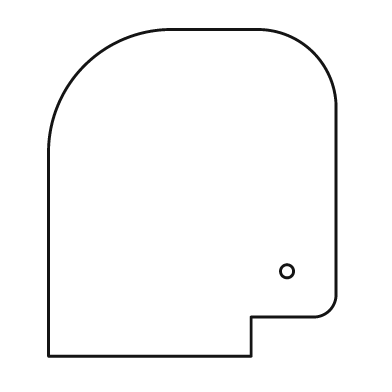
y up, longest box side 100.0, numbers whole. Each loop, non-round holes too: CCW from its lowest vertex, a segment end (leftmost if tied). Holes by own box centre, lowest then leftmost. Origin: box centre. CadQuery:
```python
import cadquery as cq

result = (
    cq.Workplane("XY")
    .moveTo(-44.0, -50.0)
    .lineTo(18.0, -50.0)
    .lineTo(18.0, -38.0)
    .lineTo(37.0, -38.0)
    .threePointArc((42.0, -36.0), (44.0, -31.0))
    .lineTo(44.0, 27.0)
    .threePointArc((37.0, 43.0), (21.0, 50.0))
    .lineTo(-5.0, 50.0)
    .threePointArc((-33.0, 39.0), (-44.0, 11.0))
    .close()
    .moveTo(29.0, -24.0)
    .circle(2.0)
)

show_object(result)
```